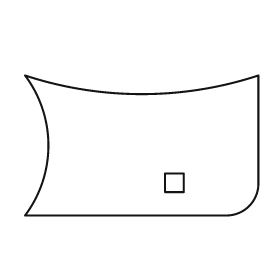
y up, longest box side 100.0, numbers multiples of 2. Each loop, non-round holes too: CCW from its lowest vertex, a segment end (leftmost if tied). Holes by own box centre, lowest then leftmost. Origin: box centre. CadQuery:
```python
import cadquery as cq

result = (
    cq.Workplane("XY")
    .moveTo(-50.0, -30.0)
    .lineTo(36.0, -30.0)
    .threePointArc((46.0, -26.0), (50.0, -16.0))
    .lineTo(50.0, 30.0)
    .threePointArc((0.0, 22.0), (-50.0, 30.0))
    .threePointArc((-40.0, 0.0), (-50.0, -30.0))
    .close()
    .moveTo(10.0, -20.0)
    .lineTo(18.0, -20.0)
    .lineTo(18.0, -12.0)
    .lineTo(10.0, -12.0)
    .close()
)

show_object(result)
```